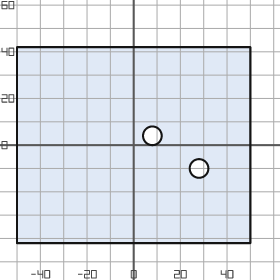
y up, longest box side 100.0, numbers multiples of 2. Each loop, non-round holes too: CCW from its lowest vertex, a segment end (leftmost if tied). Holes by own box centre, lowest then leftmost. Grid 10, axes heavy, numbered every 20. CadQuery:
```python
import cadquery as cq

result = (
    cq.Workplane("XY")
    .moveTo(-50.0, -42.0)
    .lineTo(50.0, -42.0)
    .lineTo(50.0, 42.0)
    .lineTo(-50.0, 42.0)
    .close()
    .moveTo(28.0, -10.0)
    .circle(4.0)
    .moveTo(8.0, 4.0)
    .circle(4.0)
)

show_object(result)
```